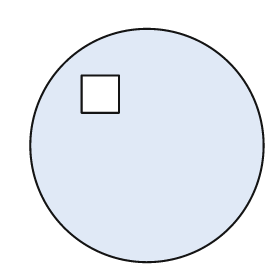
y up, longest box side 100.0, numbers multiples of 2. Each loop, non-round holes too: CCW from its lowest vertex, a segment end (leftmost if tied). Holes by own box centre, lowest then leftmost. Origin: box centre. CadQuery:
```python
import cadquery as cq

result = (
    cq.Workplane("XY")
    .moveTo(0.0, 0.0)
    .circle(50.0)
    .moveTo(-28.0, 14.0)
    .lineTo(-12.0, 14.0)
    .lineTo(-12.0, 30.0)
    .lineTo(-28.0, 30.0)
    .close()
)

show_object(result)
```